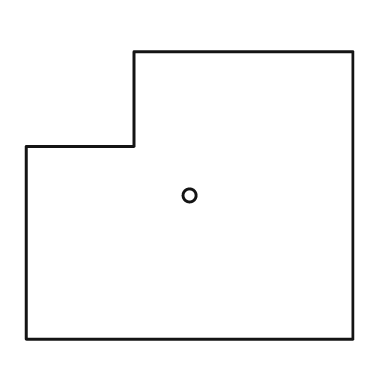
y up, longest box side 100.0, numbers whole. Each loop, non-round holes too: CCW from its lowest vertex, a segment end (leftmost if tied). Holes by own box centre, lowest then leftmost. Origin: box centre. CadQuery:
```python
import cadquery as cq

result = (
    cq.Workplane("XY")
    .moveTo(-50.0, -44.0)
    .lineTo(50.0, -44.0)
    .lineTo(50.0, 44.0)
    .lineTo(-17.0, 44.0)
    .lineTo(-17.0, 15.0)
    .lineTo(-50.0, 15.0)
    .close()
    .moveTo(0.0, 0.0)
    .circle(2.0)
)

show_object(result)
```